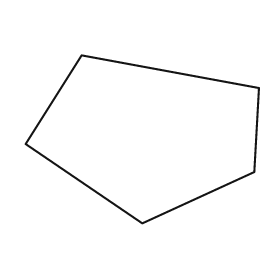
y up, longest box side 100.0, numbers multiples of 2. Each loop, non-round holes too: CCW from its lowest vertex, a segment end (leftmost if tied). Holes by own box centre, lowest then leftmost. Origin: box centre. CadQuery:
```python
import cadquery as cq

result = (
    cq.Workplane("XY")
    .moveTo(0.0, -36.0)
    .lineTo(48.0, -14.0)
    .lineTo(50.0, 22.0)
    .lineTo(-26.0, 36.0)
    .lineTo(-50.0, -2.0)
    .close()
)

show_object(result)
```